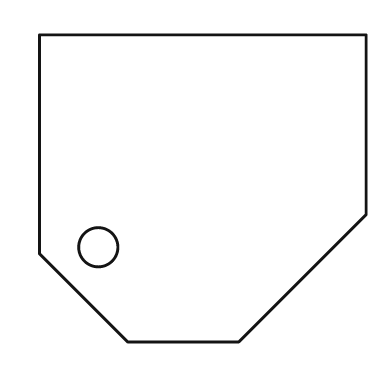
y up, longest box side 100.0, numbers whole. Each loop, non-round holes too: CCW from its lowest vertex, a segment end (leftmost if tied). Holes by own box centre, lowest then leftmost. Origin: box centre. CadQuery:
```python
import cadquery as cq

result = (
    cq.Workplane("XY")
    .moveTo(-23.0, -47.0)
    .lineTo(11.0, -47.0)
    .lineTo(50.0, -8.0)
    .lineTo(50.0, 47.0)
    .lineTo(-50.0, 47.0)
    .lineTo(-50.0, -20.0)
    .close()
    .moveTo(-32.0, -18.0)
    .circle(6.0)
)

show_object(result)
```